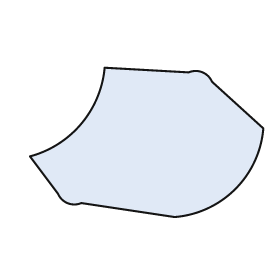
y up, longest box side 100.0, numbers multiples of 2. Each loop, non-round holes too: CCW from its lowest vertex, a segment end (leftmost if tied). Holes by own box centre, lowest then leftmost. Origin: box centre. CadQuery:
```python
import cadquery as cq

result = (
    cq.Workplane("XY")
    .moveTo(12.0, -32.0)
    .threePointArc((38.0, -20.0), (50.0, 6.0))
    .lineTo(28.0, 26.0)
    .threePointArc((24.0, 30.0), (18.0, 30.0))
    .lineTo(-18.0, 32.0)
    .threePointArc((-28.0, 8.0), (-50.0, -6.0))
    .lineTo(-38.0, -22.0)
    .threePointArc((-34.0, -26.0), (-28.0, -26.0))
    .close()
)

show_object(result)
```